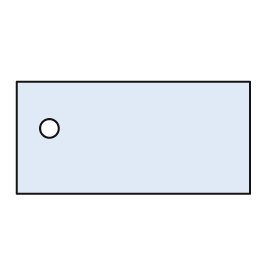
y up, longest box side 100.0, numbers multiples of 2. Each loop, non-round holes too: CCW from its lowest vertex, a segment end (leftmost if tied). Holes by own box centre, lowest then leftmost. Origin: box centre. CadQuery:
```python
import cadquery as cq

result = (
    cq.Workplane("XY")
    .moveTo(-50.0, -24.0)
    .lineTo(50.0, -24.0)
    .lineTo(50.0, 24.0)
    .lineTo(-50.0, 24.0)
    .close()
    .moveTo(-36.0, 4.0)
    .circle(4.0)
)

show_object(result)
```